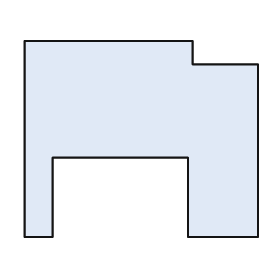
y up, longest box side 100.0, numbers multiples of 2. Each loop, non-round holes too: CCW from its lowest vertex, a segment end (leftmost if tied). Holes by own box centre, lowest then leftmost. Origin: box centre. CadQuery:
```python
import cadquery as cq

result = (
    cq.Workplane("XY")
    .moveTo(-50.0, -42.0)
    .lineTo(-38.0, -42.0)
    .lineTo(-38.0, -8.0)
    .lineTo(20.0, -8.0)
    .lineTo(20.0, -42.0)
    .lineTo(50.0, -42.0)
    .lineTo(50.0, 32.0)
    .lineTo(22.0, 32.0)
    .lineTo(22.0, 42.0)
    .lineTo(-50.0, 42.0)
    .close()
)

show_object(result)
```